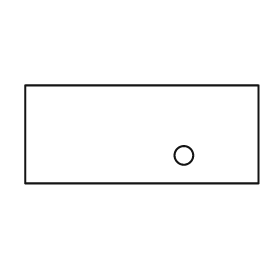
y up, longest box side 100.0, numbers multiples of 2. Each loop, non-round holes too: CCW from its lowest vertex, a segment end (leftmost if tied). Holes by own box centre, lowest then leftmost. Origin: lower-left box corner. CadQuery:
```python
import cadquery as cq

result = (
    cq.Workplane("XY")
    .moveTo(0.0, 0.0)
    .lineTo(100.0, 0.0)
    .lineTo(100.0, 42.0)
    .lineTo(0.0, 42.0)
    .close()
    .moveTo(68.0, 12.0)
    .circle(4.0)
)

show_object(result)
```